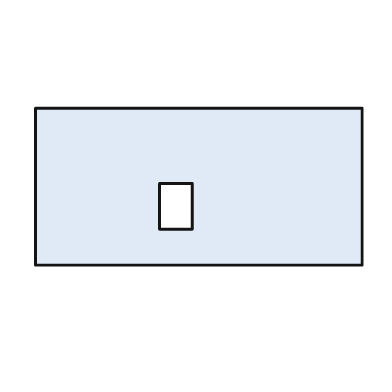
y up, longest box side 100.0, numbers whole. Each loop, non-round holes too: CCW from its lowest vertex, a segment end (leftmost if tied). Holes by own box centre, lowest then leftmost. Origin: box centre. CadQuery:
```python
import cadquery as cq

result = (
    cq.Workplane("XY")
    .moveTo(-50.0, -24.0)
    .lineTo(50.0, -24.0)
    .lineTo(50.0, 24.0)
    .lineTo(-50.0, 24.0)
    .close()
    .moveTo(-12.0, -13.0)
    .lineTo(-2.0, -13.0)
    .lineTo(-2.0, 1.0)
    .lineTo(-12.0, 1.0)
    .close()
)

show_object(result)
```